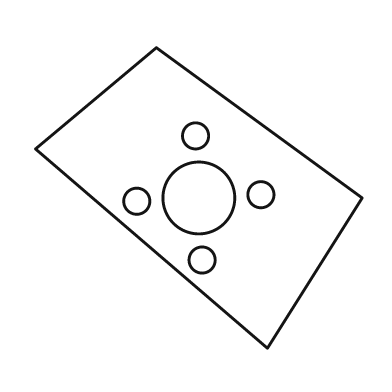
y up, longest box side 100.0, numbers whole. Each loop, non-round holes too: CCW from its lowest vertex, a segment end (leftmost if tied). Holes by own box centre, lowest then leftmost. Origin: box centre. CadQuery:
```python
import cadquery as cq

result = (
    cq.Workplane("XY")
    .moveTo(21.0, -46.0)
    .lineTo(50.0, 0.0)
    .lineTo(-13.0, 46.0)
    .lineTo(-50.0, 15.0)
    .close()
    .moveTo(1.0, -19.0)
    .circle(4.0)
    .moveTo(-19.0, -1.0)
    .circle(4.0)
    .moveTo(0.0, 0.0)
    .circle(11.0)
    .moveTo(19.0, 1.0)
    .circle(4.0)
    .moveTo(-1.0, 19.0)
    .circle(4.0)
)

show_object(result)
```